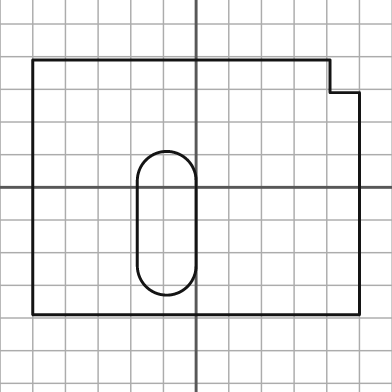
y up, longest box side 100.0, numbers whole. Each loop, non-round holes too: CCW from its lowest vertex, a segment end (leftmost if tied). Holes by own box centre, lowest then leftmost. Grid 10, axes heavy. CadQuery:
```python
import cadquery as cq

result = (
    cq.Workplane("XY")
    .moveTo(-50.0, -39.0)
    .lineTo(50.0, -39.0)
    .lineTo(50.0, 29.0)
    .lineTo(41.0, 29.0)
    .lineTo(41.0, 39.0)
    .lineTo(-50.0, 39.0)
    .close()
    .moveTo(-18.0, -24.0)
    .threePointArc((-9.0, -33.0), (0.0, -24.0))
    .lineTo(0.0, 2.0)
    .threePointArc((-9.0, 11.0), (-18.0, 2.0))
    .close()
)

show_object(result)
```